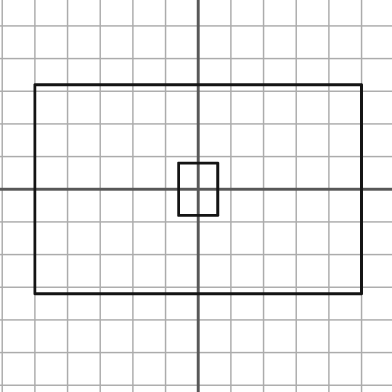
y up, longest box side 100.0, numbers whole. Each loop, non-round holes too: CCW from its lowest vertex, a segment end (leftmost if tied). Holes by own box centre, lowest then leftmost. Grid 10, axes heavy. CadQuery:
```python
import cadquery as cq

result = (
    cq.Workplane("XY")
    .moveTo(-50.0, -32.0)
    .lineTo(50.0, -32.0)
    .lineTo(50.0, 32.0)
    .lineTo(-50.0, 32.0)
    .close()
    .moveTo(-6.0, -8.0)
    .lineTo(6.0, -8.0)
    .lineTo(6.0, 8.0)
    .lineTo(-6.0, 8.0)
    .close()
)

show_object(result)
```